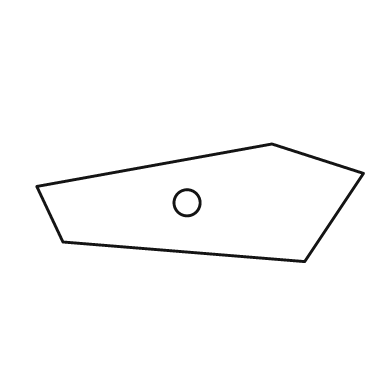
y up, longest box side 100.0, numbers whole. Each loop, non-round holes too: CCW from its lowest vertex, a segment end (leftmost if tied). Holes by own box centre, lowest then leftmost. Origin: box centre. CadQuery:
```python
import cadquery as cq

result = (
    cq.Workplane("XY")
    .moveTo(32.0, -18.0)
    .lineTo(50.0, 9.0)
    .lineTo(22.0, 18.0)
    .lineTo(-50.0, 5.0)
    .lineTo(-42.0, -12.0)
    .close()
    .moveTo(-4.0, 0.0)
    .circle(4.0)
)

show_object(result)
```